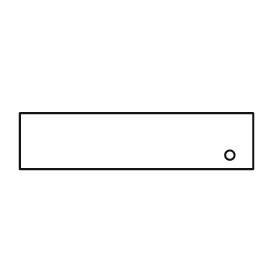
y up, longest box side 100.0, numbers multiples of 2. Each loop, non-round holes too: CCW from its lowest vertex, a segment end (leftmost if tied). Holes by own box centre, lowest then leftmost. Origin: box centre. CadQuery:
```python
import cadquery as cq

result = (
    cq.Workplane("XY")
    .moveTo(-50.0, -12.0)
    .lineTo(50.0, -12.0)
    .lineTo(50.0, 12.0)
    .lineTo(-50.0, 12.0)
    .close()
    .moveTo(40.0, -6.0)
    .circle(2.0)
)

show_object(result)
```